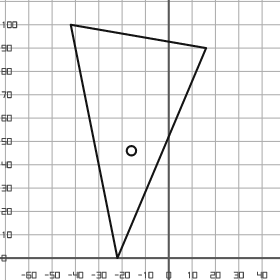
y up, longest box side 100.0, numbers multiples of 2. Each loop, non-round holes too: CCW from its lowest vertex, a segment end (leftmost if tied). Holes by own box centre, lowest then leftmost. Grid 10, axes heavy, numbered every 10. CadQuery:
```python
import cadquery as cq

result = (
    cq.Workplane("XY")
    .moveTo(-22.0, 0.0)
    .lineTo(16.0, 90.0)
    .lineTo(-42.0, 100.0)
    .close()
    .moveTo(-16.0, 46.0)
    .circle(2.0)
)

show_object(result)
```